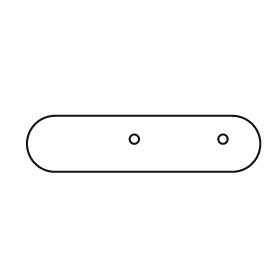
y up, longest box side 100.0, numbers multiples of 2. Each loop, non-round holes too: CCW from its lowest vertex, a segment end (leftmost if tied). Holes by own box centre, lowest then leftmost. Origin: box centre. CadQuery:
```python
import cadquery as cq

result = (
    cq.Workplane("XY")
    .moveTo(-38.0, -12.0)
    .lineTo(38.0, -12.0)
    .threePointArc((50.0, 0.0), (38.0, 12.0))
    .lineTo(-38.0, 12.0)
    .threePointArc((-50.0, 0.0), (-38.0, -12.0))
    .close()
    .moveTo(-4.0, 2.0)
    .circle(2.0)
    .moveTo(34.0, 2.0)
    .circle(2.0)
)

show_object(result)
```